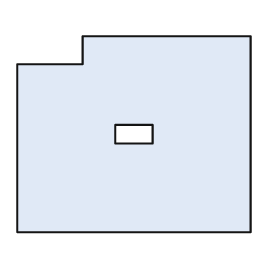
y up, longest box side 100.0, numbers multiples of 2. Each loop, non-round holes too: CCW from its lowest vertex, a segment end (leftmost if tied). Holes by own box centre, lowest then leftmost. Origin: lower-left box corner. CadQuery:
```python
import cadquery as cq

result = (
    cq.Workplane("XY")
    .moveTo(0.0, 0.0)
    .lineTo(100.0, 0.0)
    .lineTo(100.0, 84.0)
    .lineTo(28.0, 84.0)
    .lineTo(28.0, 72.0)
    .lineTo(0.0, 72.0)
    .close()
    .moveTo(42.0, 38.0)
    .lineTo(58.0, 38.0)
    .lineTo(58.0, 46.0)
    .lineTo(42.0, 46.0)
    .close()
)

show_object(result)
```